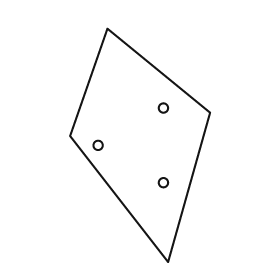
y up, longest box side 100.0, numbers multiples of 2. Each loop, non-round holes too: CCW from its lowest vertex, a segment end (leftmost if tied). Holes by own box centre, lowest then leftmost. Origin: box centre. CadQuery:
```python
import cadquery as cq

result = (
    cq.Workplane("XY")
    .moveTo(12.0, -50.0)
    .lineTo(30.0, 14.0)
    .lineTo(-14.0, 50.0)
    .lineTo(-30.0, 4.0)
    .close()
    .moveTo(10.0, -16.0)
    .circle(2.0)
    .moveTo(-18.0, 0.0)
    .circle(2.0)
    .moveTo(10.0, 16.0)
    .circle(2.0)
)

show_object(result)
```